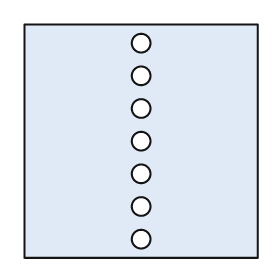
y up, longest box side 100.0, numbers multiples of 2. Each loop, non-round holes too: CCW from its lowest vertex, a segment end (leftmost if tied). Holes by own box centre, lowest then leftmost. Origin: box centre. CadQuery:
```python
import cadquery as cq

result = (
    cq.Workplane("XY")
    .moveTo(-50.0, -50.0)
    .lineTo(50.0, -50.0)
    .lineTo(50.0, 50.0)
    .lineTo(-50.0, 50.0)
    .close()
    .moveTo(0.0, -42.0)
    .circle(4.0)
    .moveTo(0.0, -28.0)
    .circle(4.0)
    .moveTo(0.0, -14.0)
    .circle(4.0)
    .moveTo(0.0, 0.0)
    .circle(4.0)
    .moveTo(0.0, 14.0)
    .circle(4.0)
    .moveTo(0.0, 28.0)
    .circle(4.0)
    .moveTo(0.0, 42.0)
    .circle(4.0)
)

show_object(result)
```